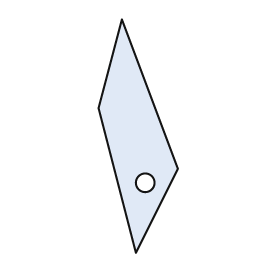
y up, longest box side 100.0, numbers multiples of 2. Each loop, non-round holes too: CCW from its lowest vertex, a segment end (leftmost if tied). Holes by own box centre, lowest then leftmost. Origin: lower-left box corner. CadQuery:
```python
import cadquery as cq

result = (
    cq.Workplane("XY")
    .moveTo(16.0, 0.0)
    .lineTo(34.0, 36.0)
    .lineTo(10.0, 100.0)
    .lineTo(0.0, 62.0)
    .close()
    .moveTo(20.0, 30.0)
    .circle(4.0)
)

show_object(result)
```